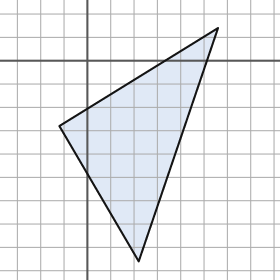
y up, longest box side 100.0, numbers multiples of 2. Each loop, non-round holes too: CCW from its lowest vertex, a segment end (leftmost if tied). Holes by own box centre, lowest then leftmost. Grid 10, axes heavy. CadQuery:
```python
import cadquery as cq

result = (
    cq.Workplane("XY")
    .moveTo(22.0, -86.0)
    .lineTo(56.0, 14.0)
    .lineTo(-12.0, -28.0)
    .close()
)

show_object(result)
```